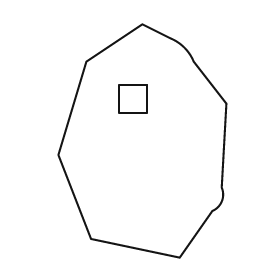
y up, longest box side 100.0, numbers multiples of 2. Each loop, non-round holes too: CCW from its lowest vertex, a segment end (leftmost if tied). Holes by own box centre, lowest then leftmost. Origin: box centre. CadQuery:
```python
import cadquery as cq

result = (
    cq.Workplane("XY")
    .moveTo(16.0, -50.0)
    .lineTo(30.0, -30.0)
    .threePointArc((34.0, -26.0), (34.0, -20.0))
    .lineTo(36.0, 16.0)
    .lineTo(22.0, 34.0)
    .threePointArc((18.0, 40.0), (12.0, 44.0))
    .lineTo(0.0, 50.0)
    .lineTo(-24.0, 34.0)
    .lineTo(-36.0, -6.0)
    .lineTo(-22.0, -42.0)
    .close()
    .moveTo(-10.0, 12.0)
    .lineTo(2.0, 12.0)
    .lineTo(2.0, 24.0)
    .lineTo(-10.0, 24.0)
    .close()
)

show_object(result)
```